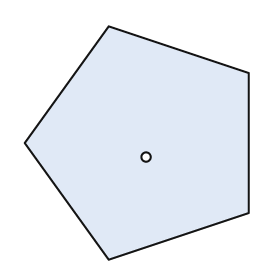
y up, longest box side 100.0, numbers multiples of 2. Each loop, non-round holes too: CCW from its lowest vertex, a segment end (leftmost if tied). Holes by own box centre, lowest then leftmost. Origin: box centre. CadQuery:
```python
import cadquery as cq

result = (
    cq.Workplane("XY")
    .moveTo(-12.0, -50.0)
    .lineTo(48.0, -30.0)
    .lineTo(48.0, 30.0)
    .lineTo(-12.0, 50.0)
    .lineTo(-48.0, 0.0)
    .close()
    .moveTo(4.0, -6.0)
    .circle(2.0)
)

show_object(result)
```